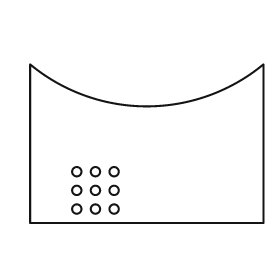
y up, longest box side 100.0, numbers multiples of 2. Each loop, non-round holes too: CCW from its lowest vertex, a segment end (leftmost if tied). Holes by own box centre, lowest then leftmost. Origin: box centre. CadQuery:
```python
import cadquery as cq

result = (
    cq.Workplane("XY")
    .moveTo(-50.0, -34.0)
    .lineTo(50.0, -34.0)
    .lineTo(50.0, 34.0)
    .threePointArc((0.0, 16.0), (-50.0, 34.0))
    .close()
    .moveTo(-30.0, -28.0)
    .circle(2.0)
    .moveTo(-22.0, -28.0)
    .circle(2.0)
    .moveTo(-14.0, -28.0)
    .circle(2.0)
    .moveTo(-30.0, -20.0)
    .circle(2.0)
    .moveTo(-22.0, -20.0)
    .circle(2.0)
    .moveTo(-14.0, -20.0)
    .circle(2.0)
    .moveTo(-30.0, -12.0)
    .circle(2.0)
    .moveTo(-22.0, -12.0)
    .circle(2.0)
    .moveTo(-14.0, -12.0)
    .circle(2.0)
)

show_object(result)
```